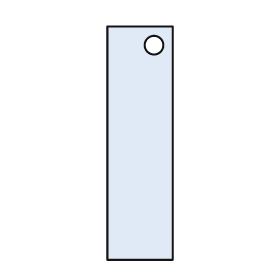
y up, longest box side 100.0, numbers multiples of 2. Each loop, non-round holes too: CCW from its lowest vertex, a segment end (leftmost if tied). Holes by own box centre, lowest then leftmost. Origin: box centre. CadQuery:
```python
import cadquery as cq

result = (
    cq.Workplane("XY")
    .moveTo(-14.0, -50.0)
    .lineTo(14.0, -50.0)
    .lineTo(14.0, 50.0)
    .lineTo(-14.0, 50.0)
    .close()
    .moveTo(6.0, 42.0)
    .circle(4.0)
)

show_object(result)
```